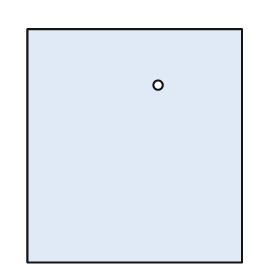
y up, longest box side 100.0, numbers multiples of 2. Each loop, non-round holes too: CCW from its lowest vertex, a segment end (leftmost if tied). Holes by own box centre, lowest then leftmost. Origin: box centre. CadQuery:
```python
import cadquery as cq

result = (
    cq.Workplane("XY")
    .moveTo(-46.0, -50.0)
    .lineTo(46.0, -50.0)
    .lineTo(46.0, 50.0)
    .lineTo(-46.0, 50.0)
    .close()
    .moveTo(10.0, 26.0)
    .circle(2.0)
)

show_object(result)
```